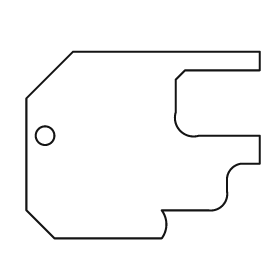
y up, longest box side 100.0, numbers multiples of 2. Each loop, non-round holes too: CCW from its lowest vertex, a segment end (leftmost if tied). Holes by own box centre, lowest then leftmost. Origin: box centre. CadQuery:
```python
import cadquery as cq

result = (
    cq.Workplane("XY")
    .moveTo(-38.0, -40.0)
    .lineTo(8.0, -40.0)
    .threePointArc((10.0, -34.0), (8.0, -28.0))
    .lineTo(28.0, -28.0)
    .threePointArc((34.0, -26.0), (36.0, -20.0))
    .lineTo(36.0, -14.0)
    .threePointArc((38.0, -10.0), (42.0, -8.0))
    .lineTo(50.0, -8.0)
    .lineTo(50.0, 4.0)
    .lineTo(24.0, 4.0)
    .threePointArc((16.0, 6.0), (14.0, 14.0))
    .lineTo(14.0, 28.0)
    .lineTo(18.0, 32.0)
    .lineTo(50.0, 32.0)
    .lineTo(50.0, 40.0)
    .lineTo(-30.0, 40.0)
    .lineTo(-50.0, 20.0)
    .lineTo(-50.0, -28.0)
    .close()
    .moveTo(-42.0, 4.0)
    .circle(4.0)
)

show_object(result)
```